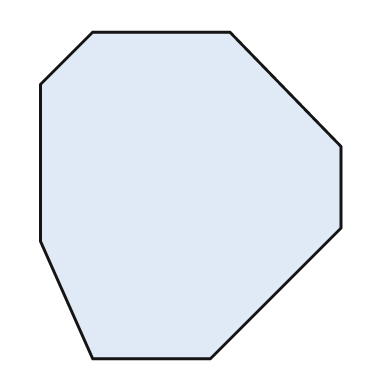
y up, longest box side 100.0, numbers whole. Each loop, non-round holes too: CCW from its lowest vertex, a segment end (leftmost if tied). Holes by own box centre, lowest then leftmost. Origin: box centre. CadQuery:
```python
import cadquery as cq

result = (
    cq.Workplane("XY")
    .moveTo(-30.0, -50.0)
    .lineTo(6.0, -50.0)
    .lineTo(46.0, -10.0)
    .lineTo(46.0, 15.0)
    .lineTo(12.0, 50.0)
    .lineTo(-30.0, 50.0)
    .lineTo(-46.0, 34.0)
    .lineTo(-46.0, -14.0)
    .close()
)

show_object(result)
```